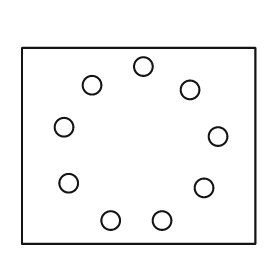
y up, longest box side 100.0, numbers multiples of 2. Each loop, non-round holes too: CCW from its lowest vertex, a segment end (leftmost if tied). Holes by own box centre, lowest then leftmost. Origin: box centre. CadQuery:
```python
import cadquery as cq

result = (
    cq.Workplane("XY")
    .moveTo(-50.0, -42.0)
    .lineTo(50.0, -42.0)
    .lineTo(50.0, 42.0)
    .lineTo(-50.0, 42.0)
    .close()
    .moveTo(-12.0, -32.0)
    .circle(4.0)
    .moveTo(10.0, -32.0)
    .circle(4.0)
    .moveTo(28.0, -18.0)
    .circle(4.0)
    .moveTo(-30.0, -16.0)
    .circle(4.0)
    .moveTo(34.0, 4.0)
    .circle(4.0)
    .moveTo(-32.0, 8.0)
    .circle(4.0)
    .moveTo(22.0, 24.0)
    .circle(4.0)
    .moveTo(-20.0, 26.0)
    .circle(4.0)
    .moveTo(2.0, 34.0)
    .circle(4.0)
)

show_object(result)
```